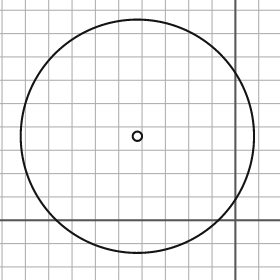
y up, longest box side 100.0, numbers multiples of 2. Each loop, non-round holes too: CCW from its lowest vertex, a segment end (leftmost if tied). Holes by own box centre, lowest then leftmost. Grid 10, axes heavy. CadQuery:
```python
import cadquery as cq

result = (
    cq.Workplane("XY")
    .moveTo(-42.0, 36.0)
    .circle(50.0)
    .moveTo(-42.0, 36.0)
    .circle(2.0)
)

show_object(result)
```